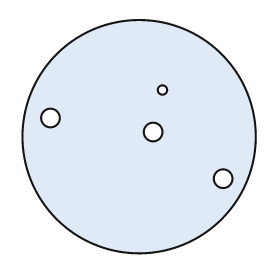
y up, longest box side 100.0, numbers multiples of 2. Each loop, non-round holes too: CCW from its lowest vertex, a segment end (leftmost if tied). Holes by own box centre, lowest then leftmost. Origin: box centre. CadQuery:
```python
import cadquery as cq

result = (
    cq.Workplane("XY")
    .moveTo(0.0, 0.0)
    .circle(50.0)
    .moveTo(36.0, -18.0)
    .circle(4.0)
    .moveTo(6.0, 2.0)
    .circle(4.0)
    .moveTo(-38.0, 8.0)
    .circle(4.0)
    .moveTo(10.0, 20.0)
    .circle(2.0)
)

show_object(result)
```